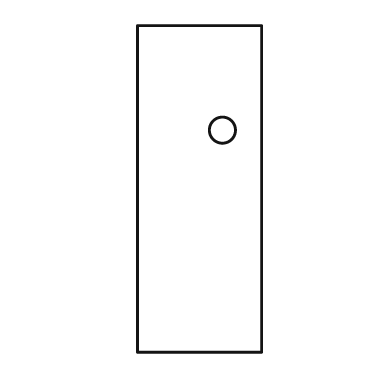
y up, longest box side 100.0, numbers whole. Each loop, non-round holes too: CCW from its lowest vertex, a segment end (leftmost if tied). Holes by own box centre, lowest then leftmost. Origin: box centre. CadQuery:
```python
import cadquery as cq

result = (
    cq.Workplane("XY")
    .moveTo(-19.0, -50.0)
    .lineTo(19.0, -50.0)
    .lineTo(19.0, 50.0)
    .lineTo(-19.0, 50.0)
    .close()
    .moveTo(7.0, 18.0)
    .circle(4.0)
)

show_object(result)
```